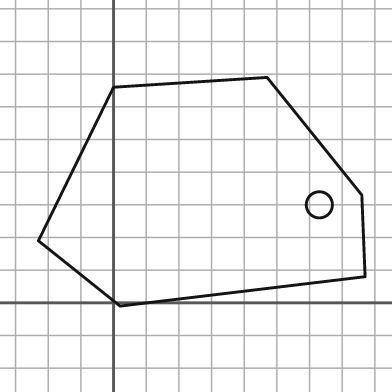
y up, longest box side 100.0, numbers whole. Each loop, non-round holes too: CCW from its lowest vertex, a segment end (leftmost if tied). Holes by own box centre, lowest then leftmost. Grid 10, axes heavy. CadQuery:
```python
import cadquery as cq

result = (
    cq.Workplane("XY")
    .moveTo(2.0, -1.0)
    .lineTo(77.0, 8.0)
    .lineTo(76.0, 33.0)
    .lineTo(47.0, 69.0)
    .lineTo(0.0, 66.0)
    .lineTo(-23.0, 19.0)
    .close()
    .moveTo(63.0, 30.0)
    .circle(4.0)
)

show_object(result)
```